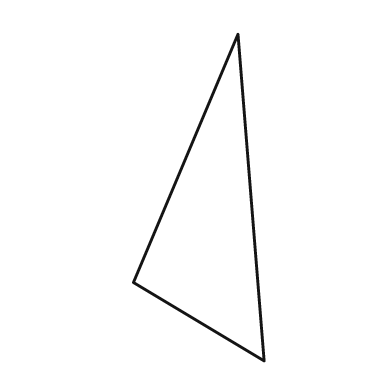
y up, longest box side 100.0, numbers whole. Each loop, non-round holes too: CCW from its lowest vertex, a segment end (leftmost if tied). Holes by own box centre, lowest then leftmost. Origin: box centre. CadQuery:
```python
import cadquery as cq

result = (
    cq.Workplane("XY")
    .moveTo(20.0, -50.0)
    .lineTo(12.0, 50.0)
    .lineTo(-20.0, -26.0)
    .close()
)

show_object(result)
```